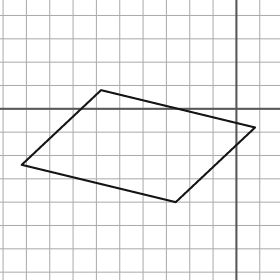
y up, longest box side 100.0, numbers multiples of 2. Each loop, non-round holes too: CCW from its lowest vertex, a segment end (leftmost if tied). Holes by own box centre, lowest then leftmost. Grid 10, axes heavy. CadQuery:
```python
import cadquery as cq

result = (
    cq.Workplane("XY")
    .moveTo(-26.0, -40.0)
    .lineTo(8.0, -8.0)
    .lineTo(-58.0, 8.0)
    .lineTo(-92.0, -24.0)
    .close()
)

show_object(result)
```